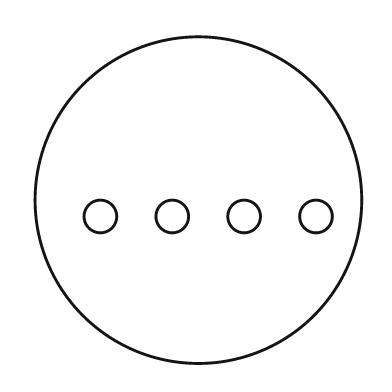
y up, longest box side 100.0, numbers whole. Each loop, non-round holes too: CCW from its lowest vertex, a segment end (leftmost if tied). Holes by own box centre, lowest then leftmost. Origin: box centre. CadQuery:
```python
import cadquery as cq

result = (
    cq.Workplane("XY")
    .moveTo(0.0, 0.0)
    .circle(50.0)
    .moveTo(-30.0, -5.0)
    .circle(5.0)
    .moveTo(-8.0, -5.0)
    .circle(5.0)
    .moveTo(14.0, -5.0)
    .circle(5.0)
    .moveTo(36.0, -5.0)
    .circle(5.0)
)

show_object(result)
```